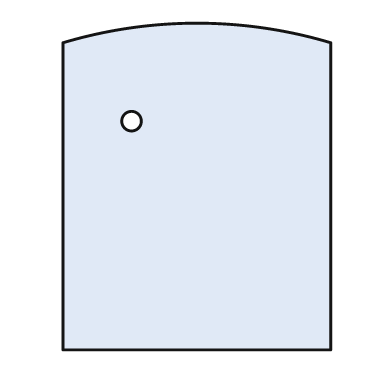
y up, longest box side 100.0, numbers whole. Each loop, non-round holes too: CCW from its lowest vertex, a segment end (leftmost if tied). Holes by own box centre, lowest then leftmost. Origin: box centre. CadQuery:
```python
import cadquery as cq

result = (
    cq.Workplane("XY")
    .moveTo(-41.0, -50.0)
    .lineTo(41.0, -50.0)
    .lineTo(41.0, 44.0)
    .threePointArc((0.0, 50.0), (-41.0, 44.0))
    .close()
    .moveTo(-20.0, 20.0)
    .circle(3.0)
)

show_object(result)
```